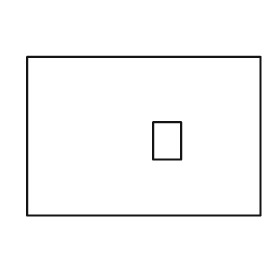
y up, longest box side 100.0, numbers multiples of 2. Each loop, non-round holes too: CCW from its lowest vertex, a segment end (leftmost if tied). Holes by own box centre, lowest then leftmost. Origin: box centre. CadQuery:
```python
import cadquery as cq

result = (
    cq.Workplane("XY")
    .moveTo(-50.0, -34.0)
    .lineTo(50.0, -34.0)
    .lineTo(50.0, 34.0)
    .lineTo(-50.0, 34.0)
    .close()
    .moveTo(4.0, -10.0)
    .lineTo(16.0, -10.0)
    .lineTo(16.0, 6.0)
    .lineTo(4.0, 6.0)
    .close()
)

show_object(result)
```